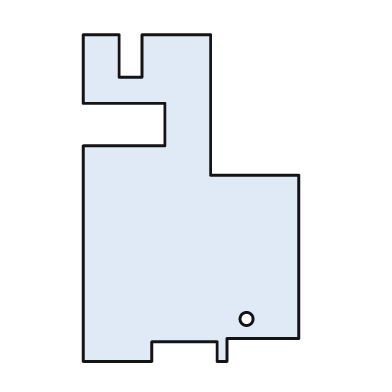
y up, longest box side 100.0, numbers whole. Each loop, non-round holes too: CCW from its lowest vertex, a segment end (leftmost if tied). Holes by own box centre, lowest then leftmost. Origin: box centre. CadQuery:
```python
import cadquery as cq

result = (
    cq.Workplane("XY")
    .moveTo(-33.0, -50.0)
    .lineTo(-12.0, -50.0)
    .lineTo(-12.0, -44.0)
    .lineTo(8.0, -44.0)
    .lineTo(8.0, -50.0)
    .lineTo(11.0, -50.0)
    .lineTo(11.0, -43.0)
    .lineTo(33.0, -43.0)
    .lineTo(33.0, 7.0)
    .lineTo(6.0, 7.0)
    .lineTo(6.0, 50.0)
    .lineTo(-15.0, 50.0)
    .lineTo(-15.0, 37.0)
    .lineTo(-22.0, 37.0)
    .lineTo(-22.0, 50.0)
    .lineTo(-33.0, 50.0)
    .lineTo(-33.0, 29.0)
    .lineTo(-8.0, 29.0)
    .lineTo(-8.0, 16.0)
    .lineTo(-33.0, 16.0)
    .close()
    .moveTo(17.0, -37.0)
    .circle(2.0)
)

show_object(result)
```